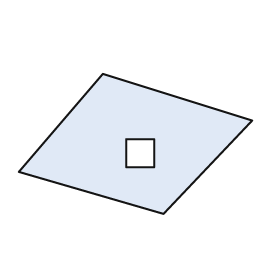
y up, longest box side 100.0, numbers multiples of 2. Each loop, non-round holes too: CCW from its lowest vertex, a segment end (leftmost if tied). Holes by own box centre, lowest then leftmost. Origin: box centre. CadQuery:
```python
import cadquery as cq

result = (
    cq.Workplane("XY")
    .moveTo(12.0, -30.0)
    .lineTo(50.0, 10.0)
    .lineTo(-14.0, 30.0)
    .lineTo(-50.0, -12.0)
    .close()
    .moveTo(-4.0, -10.0)
    .lineTo(8.0, -10.0)
    .lineTo(8.0, 2.0)
    .lineTo(-4.0, 2.0)
    .close()
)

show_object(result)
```